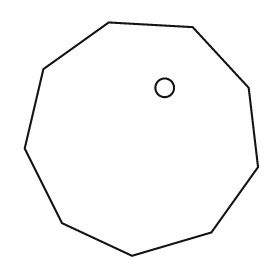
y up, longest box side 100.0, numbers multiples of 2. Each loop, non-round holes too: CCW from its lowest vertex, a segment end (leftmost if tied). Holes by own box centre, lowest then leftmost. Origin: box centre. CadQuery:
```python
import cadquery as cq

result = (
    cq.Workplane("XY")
    .moveTo(-4.0, -50.0)
    .lineTo(30.0, -40.0)
    .lineTo(50.0, -12.0)
    .lineTo(46.0, 22.0)
    .lineTo(22.0, 48.0)
    .lineTo(-14.0, 50.0)
    .lineTo(-42.0, 30.0)
    .lineTo(-50.0, -4.0)
    .lineTo(-34.0, -36.0)
    .close()
    .moveTo(10.0, 22.0)
    .circle(4.0)
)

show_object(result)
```